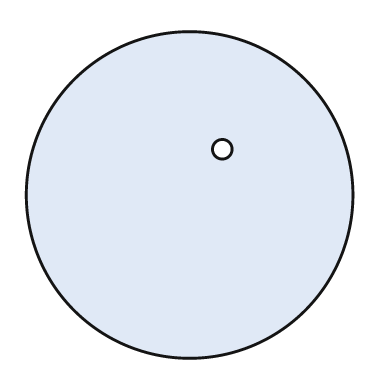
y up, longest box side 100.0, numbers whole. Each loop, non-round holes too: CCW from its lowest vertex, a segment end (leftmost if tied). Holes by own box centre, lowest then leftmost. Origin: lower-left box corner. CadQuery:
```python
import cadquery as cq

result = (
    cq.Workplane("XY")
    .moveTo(50.0, 50.0)
    .circle(50.0)
    .moveTo(60.0, 64.0)
    .circle(3.0)
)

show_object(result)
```